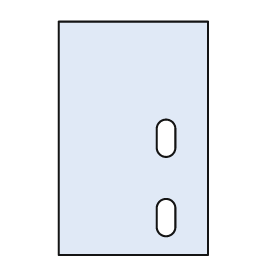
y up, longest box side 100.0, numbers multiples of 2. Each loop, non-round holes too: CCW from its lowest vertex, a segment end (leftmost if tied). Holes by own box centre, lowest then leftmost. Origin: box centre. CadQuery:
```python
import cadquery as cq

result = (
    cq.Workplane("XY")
    .moveTo(-32.0, -50.0)
    .lineTo(32.0, -50.0)
    .lineTo(32.0, 50.0)
    .lineTo(-32.0, 50.0)
    .close()
    .moveTo(10.0, -38.0)
    .threePointArc((14.0, -42.0), (18.0, -38.0))
    .lineTo(18.0, -30.0)
    .threePointArc((14.0, -26.0), (10.0, -30.0))
    .close()
    .moveTo(10.0, -4.0)
    .threePointArc((14.0, -8.0), (18.0, -4.0))
    .lineTo(18.0, 4.0)
    .threePointArc((14.0, 8.0), (10.0, 4.0))
    .close()
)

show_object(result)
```